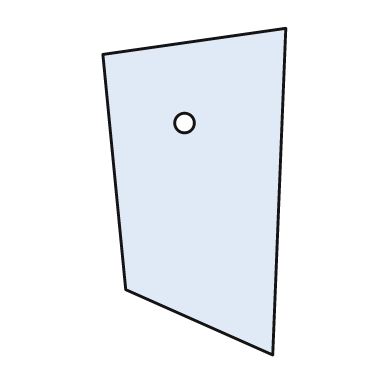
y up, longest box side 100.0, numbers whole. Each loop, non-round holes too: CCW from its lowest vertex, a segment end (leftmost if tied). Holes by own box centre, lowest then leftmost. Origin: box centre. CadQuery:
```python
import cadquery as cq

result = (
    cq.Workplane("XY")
    .moveTo(24.0, -50.0)
    .lineTo(28.0, 50.0)
    .lineTo(-28.0, 42.0)
    .lineTo(-21.0, -30.0)
    .close()
    .moveTo(-3.0, 21.0)
    .circle(3.0)
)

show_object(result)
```